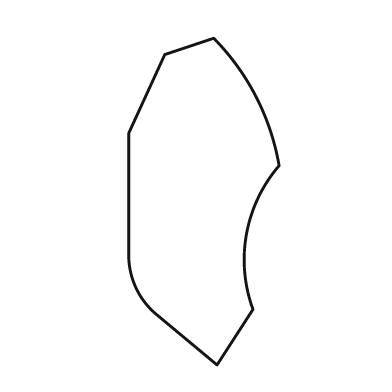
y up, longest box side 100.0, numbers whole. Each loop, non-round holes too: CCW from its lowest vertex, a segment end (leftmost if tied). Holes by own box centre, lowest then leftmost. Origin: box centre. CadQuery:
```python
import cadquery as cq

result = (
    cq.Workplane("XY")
    .moveTo(4.0, -50.0)
    .lineTo(15.0, -33.0)
    .threePointArc((13.0, -10.0), (23.0, 11.0))
    .threePointArc((16.0, 32.0), (3.0, 50.0))
    .lineTo(-12.0, 45.0)
    .lineTo(-23.0, 21.0)
    .lineTo(-23.0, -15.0)
    .threePointArc((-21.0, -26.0), (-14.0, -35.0))
    .close()
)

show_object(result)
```